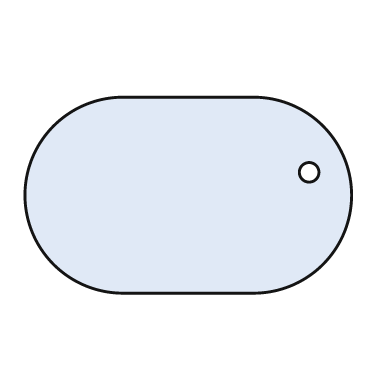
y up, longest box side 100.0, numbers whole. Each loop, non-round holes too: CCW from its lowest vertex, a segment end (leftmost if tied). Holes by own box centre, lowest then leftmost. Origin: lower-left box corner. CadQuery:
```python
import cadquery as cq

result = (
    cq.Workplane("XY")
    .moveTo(30.0, 0.0)
    .lineTo(70.0, 0.0)
    .threePointArc((100.0, 30.0), (70.0, 60.0))
    .lineTo(30.0, 60.0)
    .threePointArc((0.0, 30.0), (30.0, 0.0))
    .close()
    .moveTo(87.0, 37.0)
    .circle(3.0)
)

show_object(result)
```